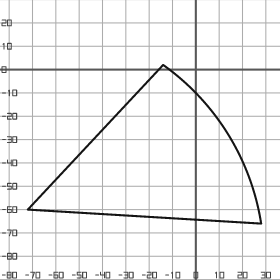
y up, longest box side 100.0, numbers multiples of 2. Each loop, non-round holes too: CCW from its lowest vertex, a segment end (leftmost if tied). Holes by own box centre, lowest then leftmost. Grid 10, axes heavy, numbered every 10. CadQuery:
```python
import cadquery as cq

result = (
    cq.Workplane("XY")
    .moveTo(28.0, -66.0)
    .threePointArc((14.0, -28.0), (-14.0, 2.0))
    .lineTo(-72.0, -60.0)
    .close()
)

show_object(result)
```